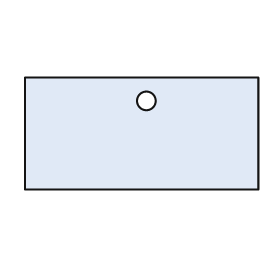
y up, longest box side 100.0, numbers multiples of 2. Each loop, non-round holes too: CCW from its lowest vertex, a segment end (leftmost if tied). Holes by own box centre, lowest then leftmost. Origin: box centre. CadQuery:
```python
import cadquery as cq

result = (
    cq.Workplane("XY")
    .moveTo(-50.0, -24.0)
    .lineTo(50.0, -24.0)
    .lineTo(50.0, 24.0)
    .lineTo(-50.0, 24.0)
    .close()
    .moveTo(2.0, 14.0)
    .circle(4.0)
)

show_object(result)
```